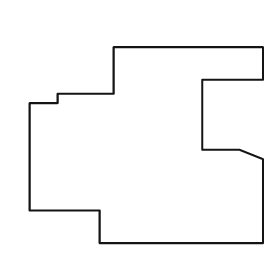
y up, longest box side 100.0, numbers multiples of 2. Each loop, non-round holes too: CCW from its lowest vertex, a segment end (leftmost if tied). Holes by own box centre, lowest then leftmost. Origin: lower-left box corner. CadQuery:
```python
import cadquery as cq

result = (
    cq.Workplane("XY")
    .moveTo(30.0, 0.0)
    .lineTo(100.0, 0.0)
    .lineTo(100.0, 36.0)
    .lineTo(90.0, 40.0)
    .lineTo(74.0, 40.0)
    .lineTo(74.0, 70.0)
    .lineTo(100.0, 70.0)
    .lineTo(100.0, 84.0)
    .lineTo(36.0, 84.0)
    .lineTo(36.0, 64.0)
    .lineTo(12.0, 64.0)
    .lineTo(12.0, 60.0)
    .lineTo(0.0, 60.0)
    .lineTo(0.0, 14.0)
    .lineTo(30.0, 14.0)
    .close()
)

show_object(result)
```